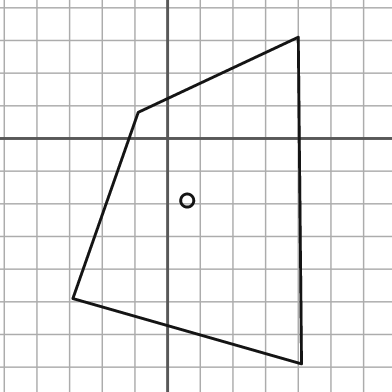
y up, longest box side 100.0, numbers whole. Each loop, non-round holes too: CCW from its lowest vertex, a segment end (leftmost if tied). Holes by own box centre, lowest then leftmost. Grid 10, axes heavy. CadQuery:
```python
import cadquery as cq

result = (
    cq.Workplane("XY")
    .moveTo(41.0, -69.0)
    .lineTo(40.0, 31.0)
    .lineTo(-9.0, 8.0)
    .lineTo(-29.0, -49.0)
    .close()
    .moveTo(6.0, -19.0)
    .circle(2.0)
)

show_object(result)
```